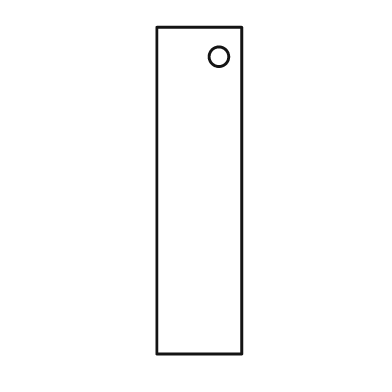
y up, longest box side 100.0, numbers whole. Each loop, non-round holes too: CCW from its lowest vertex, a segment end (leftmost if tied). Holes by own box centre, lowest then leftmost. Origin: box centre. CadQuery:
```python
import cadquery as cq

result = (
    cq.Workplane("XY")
    .moveTo(-13.0, -50.0)
    .lineTo(13.0, -50.0)
    .lineTo(13.0, 50.0)
    .lineTo(-13.0, 50.0)
    .close()
    .moveTo(6.0, 41.0)
    .circle(3.0)
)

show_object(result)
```